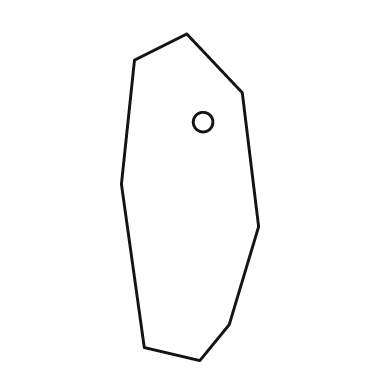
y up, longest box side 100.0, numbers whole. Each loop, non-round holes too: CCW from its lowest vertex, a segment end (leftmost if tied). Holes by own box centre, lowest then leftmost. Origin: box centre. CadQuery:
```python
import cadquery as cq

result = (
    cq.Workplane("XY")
    .moveTo(3.0, -50.0)
    .lineTo(12.0, -39.0)
    .lineTo(21.0, -9.0)
    .lineTo(16.0, 32.0)
    .lineTo(-1.0, 50.0)
    .lineTo(-17.0, 42.0)
    .lineTo(-21.0, 4.0)
    .lineTo(-14.0, -46.0)
    .close()
    .moveTo(4.0, 23.0)
    .circle(3.0)
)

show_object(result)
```